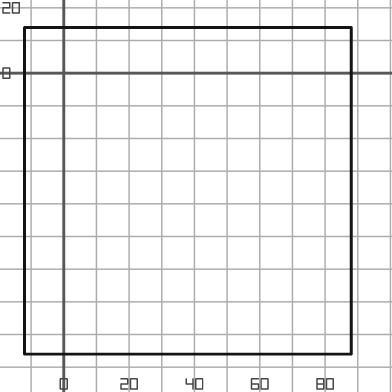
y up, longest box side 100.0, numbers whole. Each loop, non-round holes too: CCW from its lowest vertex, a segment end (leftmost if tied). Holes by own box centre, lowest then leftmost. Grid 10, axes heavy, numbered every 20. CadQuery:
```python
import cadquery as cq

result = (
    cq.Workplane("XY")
    .moveTo(-12.0, -86.0)
    .lineTo(88.0, -86.0)
    .lineTo(88.0, 14.0)
    .lineTo(-12.0, 14.0)
    .close()
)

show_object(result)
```